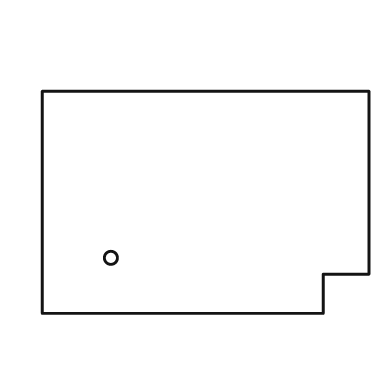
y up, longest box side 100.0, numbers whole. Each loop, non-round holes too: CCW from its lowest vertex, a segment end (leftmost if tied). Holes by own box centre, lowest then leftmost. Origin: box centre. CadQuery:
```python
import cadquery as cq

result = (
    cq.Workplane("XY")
    .moveTo(-50.0, -34.0)
    .lineTo(36.0, -34.0)
    .lineTo(36.0, -22.0)
    .lineTo(50.0, -22.0)
    .lineTo(50.0, 34.0)
    .lineTo(-50.0, 34.0)
    .close()
    .moveTo(-29.0, -17.0)
    .circle(2.0)
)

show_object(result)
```